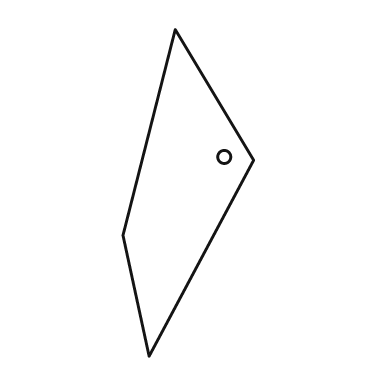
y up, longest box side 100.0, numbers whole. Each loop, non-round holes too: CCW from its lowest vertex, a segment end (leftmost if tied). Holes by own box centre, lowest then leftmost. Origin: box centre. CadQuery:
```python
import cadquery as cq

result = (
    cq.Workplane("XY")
    .moveTo(-12.0, -50.0)
    .lineTo(20.0, 10.0)
    .lineTo(-4.0, 50.0)
    .lineTo(-20.0, -13.0)
    .close()
    .moveTo(11.0, 11.0)
    .circle(2.0)
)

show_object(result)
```